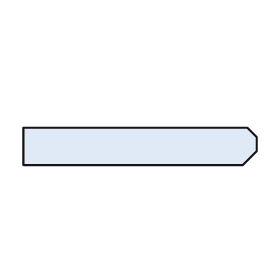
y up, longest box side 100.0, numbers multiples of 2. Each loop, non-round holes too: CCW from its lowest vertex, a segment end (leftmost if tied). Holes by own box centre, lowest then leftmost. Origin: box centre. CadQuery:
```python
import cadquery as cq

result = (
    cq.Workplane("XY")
    .moveTo(-50.0, -8.0)
    .lineTo(44.0, -8.0)
    .lineTo(50.0, -2.0)
    .lineTo(50.0, 4.0)
    .lineTo(46.0, 8.0)
    .lineTo(-50.0, 8.0)
    .close()
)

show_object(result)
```